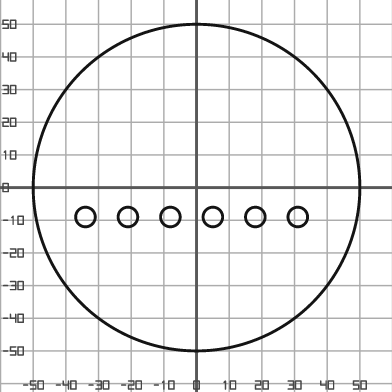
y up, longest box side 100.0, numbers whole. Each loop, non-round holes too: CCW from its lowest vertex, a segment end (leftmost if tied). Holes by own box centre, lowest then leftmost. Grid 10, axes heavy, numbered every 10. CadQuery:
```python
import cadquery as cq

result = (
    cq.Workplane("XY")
    .moveTo(0.0, 0.0)
    .circle(50.0)
    .moveTo(-34.0, -9.0)
    .circle(3.0)
    .moveTo(-21.0, -9.0)
    .circle(3.0)
    .moveTo(-8.0, -9.0)
    .circle(3.0)
    .moveTo(5.0, -9.0)
    .circle(3.0)
    .moveTo(18.0, -9.0)
    .circle(3.0)
    .moveTo(31.0, -9.0)
    .circle(3.0)
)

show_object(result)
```